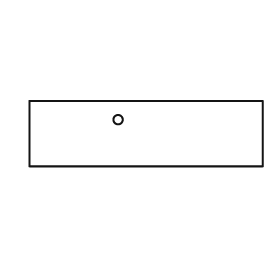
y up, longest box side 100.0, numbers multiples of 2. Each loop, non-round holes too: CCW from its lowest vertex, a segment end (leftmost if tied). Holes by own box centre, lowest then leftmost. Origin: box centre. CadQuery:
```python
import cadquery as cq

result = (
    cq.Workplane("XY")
    .moveTo(-50.0, -14.0)
    .lineTo(50.0, -14.0)
    .lineTo(50.0, 14.0)
    .lineTo(-50.0, 14.0)
    .close()
    .moveTo(-12.0, 6.0)
    .circle(2.0)
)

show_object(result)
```